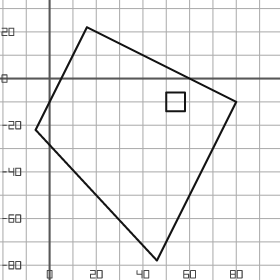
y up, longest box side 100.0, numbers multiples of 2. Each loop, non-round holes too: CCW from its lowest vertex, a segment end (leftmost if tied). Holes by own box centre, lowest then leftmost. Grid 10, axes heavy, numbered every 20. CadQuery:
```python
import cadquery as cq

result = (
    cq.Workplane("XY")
    .moveTo(46.0, -78.0)
    .lineTo(80.0, -10.0)
    .lineTo(16.0, 22.0)
    .lineTo(-6.0, -22.0)
    .close()
    .moveTo(50.0, -14.0)
    .lineTo(58.0, -14.0)
    .lineTo(58.0, -6.0)
    .lineTo(50.0, -6.0)
    .close()
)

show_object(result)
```